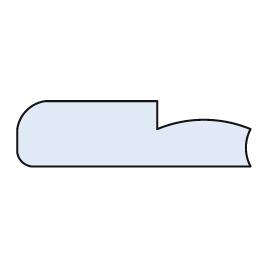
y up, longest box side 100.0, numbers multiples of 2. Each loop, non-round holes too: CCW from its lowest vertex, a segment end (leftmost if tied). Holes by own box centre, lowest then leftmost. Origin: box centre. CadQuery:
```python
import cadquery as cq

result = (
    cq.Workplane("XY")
    .moveTo(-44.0, -14.0)
    .lineTo(50.0, -14.0)
    .threePointArc((48.0, -6.0), (50.0, 2.0))
    .threePointArc((30.0, 6.0), (10.0, 2.0))
    .lineTo(10.0, 14.0)
    .lineTo(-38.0, 14.0)
    .threePointArc((-46.0, 10.0), (-50.0, 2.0))
    .lineTo(-50.0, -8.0)
    .threePointArc((-48.0, -12.0), (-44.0, -14.0))
    .close()
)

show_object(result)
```